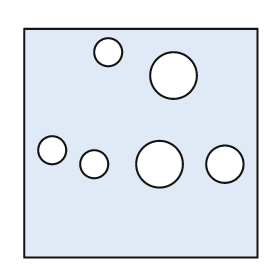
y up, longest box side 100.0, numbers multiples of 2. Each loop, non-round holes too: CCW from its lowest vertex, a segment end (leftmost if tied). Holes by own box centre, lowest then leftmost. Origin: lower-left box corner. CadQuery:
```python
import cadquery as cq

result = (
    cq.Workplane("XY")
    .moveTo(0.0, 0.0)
    .lineTo(100.0, 0.0)
    .lineTo(100.0, 98.0)
    .lineTo(0.0, 98.0)
    .close()
    .moveTo(30.0, 40.0)
    .circle(6.0)
    .moveTo(58.0, 40.0)
    .circle(10.0)
    .moveTo(86.0, 40.0)
    .circle(8.0)
    .moveTo(12.0, 46.0)
    .circle(6.0)
    .moveTo(64.0, 78.0)
    .circle(10.0)
    .moveTo(36.0, 88.0)
    .circle(6.0)
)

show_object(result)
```